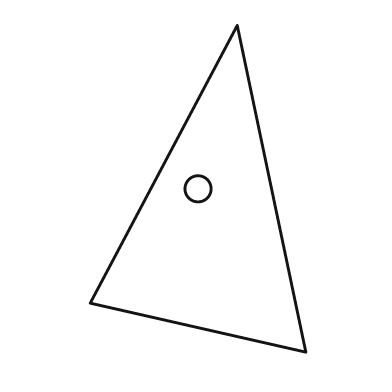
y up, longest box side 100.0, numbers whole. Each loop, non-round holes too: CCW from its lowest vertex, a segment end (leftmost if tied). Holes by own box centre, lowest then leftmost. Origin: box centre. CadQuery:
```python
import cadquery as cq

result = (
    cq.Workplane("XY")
    .moveTo(33.0, -50.0)
    .lineTo(12.0, 50.0)
    .lineTo(-33.0, -35.0)
    .close()
    .moveTo(0.0, 0.0)
    .circle(4.0)
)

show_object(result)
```